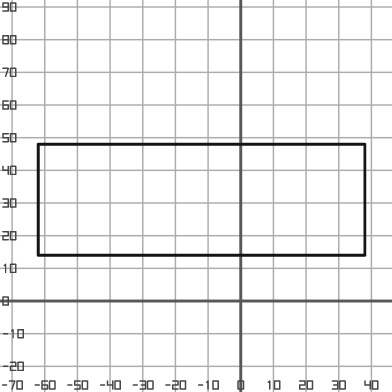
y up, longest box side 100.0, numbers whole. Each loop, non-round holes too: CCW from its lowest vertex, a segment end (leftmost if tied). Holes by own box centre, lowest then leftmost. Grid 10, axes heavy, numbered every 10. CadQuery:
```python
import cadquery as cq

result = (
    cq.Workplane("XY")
    .moveTo(-62.0, 14.0)
    .lineTo(38.0, 14.0)
    .lineTo(38.0, 48.0)
    .lineTo(-62.0, 48.0)
    .close()
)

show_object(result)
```